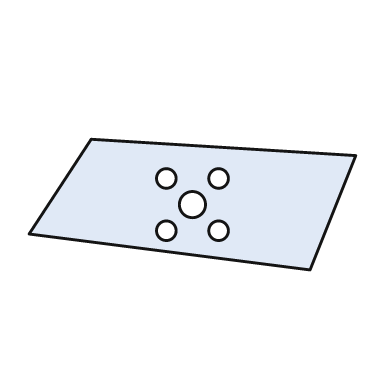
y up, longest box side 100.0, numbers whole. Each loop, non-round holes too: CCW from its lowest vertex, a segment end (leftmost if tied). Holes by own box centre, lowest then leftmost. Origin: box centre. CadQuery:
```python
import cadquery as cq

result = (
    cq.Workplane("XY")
    .moveTo(36.0, -20.0)
    .lineTo(50.0, 15.0)
    .lineTo(-31.0, 20.0)
    .lineTo(-50.0, -9.0)
    .close()
    .moveTo(-8.0, -8.0)
    .circle(3.0)
    .moveTo(8.0, -8.0)
    .circle(3.0)
    .moveTo(0.0, 0.0)
    .circle(4.0)
    .moveTo(-8.0, 8.0)
    .circle(3.0)
    .moveTo(8.0, 8.0)
    .circle(3.0)
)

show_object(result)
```